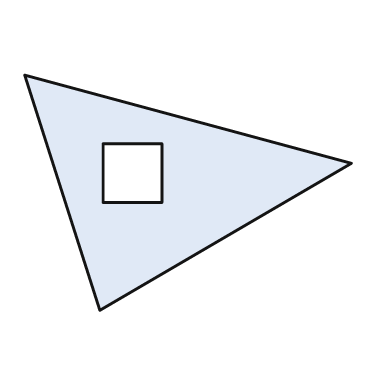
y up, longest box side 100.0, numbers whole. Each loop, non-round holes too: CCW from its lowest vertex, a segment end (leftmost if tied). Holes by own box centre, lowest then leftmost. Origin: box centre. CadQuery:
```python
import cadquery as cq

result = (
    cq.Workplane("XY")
    .moveTo(-27.0, -36.0)
    .lineTo(50.0, 9.0)
    .lineTo(-50.0, 36.0)
    .close()
    .moveTo(-26.0, -3.0)
    .lineTo(-8.0, -3.0)
    .lineTo(-8.0, 15.0)
    .lineTo(-26.0, 15.0)
    .close()
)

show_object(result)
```